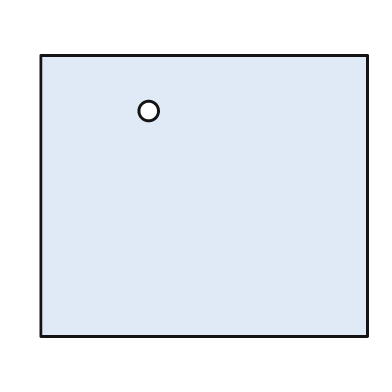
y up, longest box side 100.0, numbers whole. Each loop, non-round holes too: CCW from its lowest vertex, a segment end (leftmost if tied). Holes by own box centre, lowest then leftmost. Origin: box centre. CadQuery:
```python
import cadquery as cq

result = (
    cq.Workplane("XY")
    .moveTo(-50.0, -43.0)
    .lineTo(50.0, -43.0)
    .lineTo(50.0, 43.0)
    .lineTo(-50.0, 43.0)
    .close()
    .moveTo(-17.0, 26.0)
    .circle(3.0)
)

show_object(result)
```